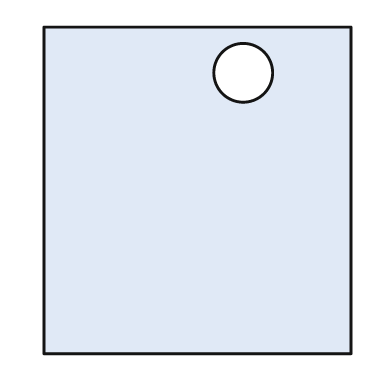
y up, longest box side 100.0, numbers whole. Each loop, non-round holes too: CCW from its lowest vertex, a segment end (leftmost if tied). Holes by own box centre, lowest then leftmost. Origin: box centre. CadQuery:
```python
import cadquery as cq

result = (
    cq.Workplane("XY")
    .moveTo(-47.0, -50.0)
    .lineTo(47.0, -50.0)
    .lineTo(47.0, 50.0)
    .lineTo(-47.0, 50.0)
    .close()
    .moveTo(14.0, 36.0)
    .circle(9.0)
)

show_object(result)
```